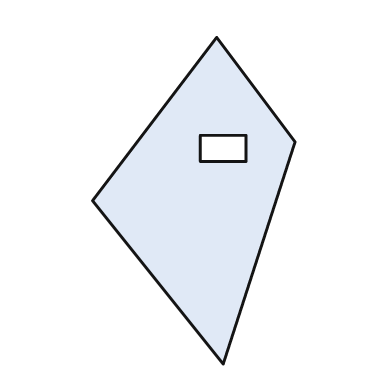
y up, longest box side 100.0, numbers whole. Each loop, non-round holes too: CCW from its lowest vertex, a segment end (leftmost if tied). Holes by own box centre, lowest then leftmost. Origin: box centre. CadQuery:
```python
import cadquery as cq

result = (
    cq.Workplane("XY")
    .moveTo(9.0, -50.0)
    .lineTo(31.0, 18.0)
    .lineTo(7.0, 50.0)
    .lineTo(-31.0, 0.0)
    .close()
    .moveTo(2.0, 12.0)
    .lineTo(16.0, 12.0)
    .lineTo(16.0, 20.0)
    .lineTo(2.0, 20.0)
    .close()
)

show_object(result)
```